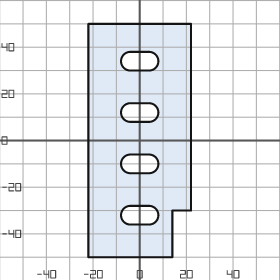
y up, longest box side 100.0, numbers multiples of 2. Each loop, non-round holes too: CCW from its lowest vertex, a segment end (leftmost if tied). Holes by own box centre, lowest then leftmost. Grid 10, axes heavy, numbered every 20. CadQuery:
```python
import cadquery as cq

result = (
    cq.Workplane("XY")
    .moveTo(-22.0, -50.0)
    .lineTo(14.0, -50.0)
    .lineTo(14.0, -30.0)
    .lineTo(22.0, -30.0)
    .lineTo(22.0, 50.0)
    .lineTo(-22.0, 50.0)
    .close()
    .moveTo(-4.0, -36.0)
    .lineTo(4.0, -36.0)
    .threePointArc((8.0, -32.0), (4.0, -28.0))
    .lineTo(-4.0, -28.0)
    .threePointArc((-8.0, -32.0), (-4.0, -36.0))
    .close()
    .moveTo(-4.0, -14.0)
    .lineTo(4.0, -14.0)
    .threePointArc((8.0, -10.0), (4.0, -6.0))
    .lineTo(-4.0, -6.0)
    .threePointArc((-8.0, -10.0), (-4.0, -14.0))
    .close()
    .moveTo(-4.0, 8.0)
    .lineTo(4.0, 8.0)
    .threePointArc((8.0, 12.0), (4.0, 16.0))
    .lineTo(-4.0, 16.0)
    .threePointArc((-8.0, 12.0), (-4.0, 8.0))
    .close()
    .moveTo(-4.0, 30.0)
    .lineTo(4.0, 30.0)
    .threePointArc((8.0, 34.0), (4.0, 38.0))
    .lineTo(-4.0, 38.0)
    .threePointArc((-8.0, 34.0), (-4.0, 30.0))
    .close()
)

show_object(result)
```